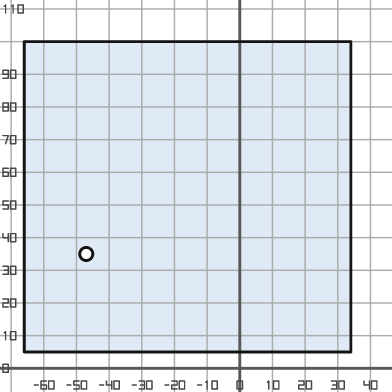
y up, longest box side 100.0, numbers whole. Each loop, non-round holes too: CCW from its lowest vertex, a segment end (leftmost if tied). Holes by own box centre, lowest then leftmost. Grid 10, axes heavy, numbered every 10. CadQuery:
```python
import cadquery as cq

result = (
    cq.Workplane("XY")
    .moveTo(-66.0, 5.0)
    .lineTo(34.0, 5.0)
    .lineTo(34.0, 100.0)
    .lineTo(-66.0, 100.0)
    .close()
    .moveTo(-47.0, 35.0)
    .circle(2.0)
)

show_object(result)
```